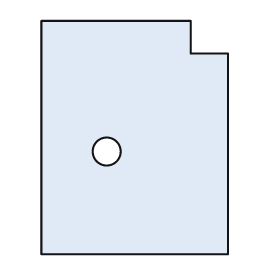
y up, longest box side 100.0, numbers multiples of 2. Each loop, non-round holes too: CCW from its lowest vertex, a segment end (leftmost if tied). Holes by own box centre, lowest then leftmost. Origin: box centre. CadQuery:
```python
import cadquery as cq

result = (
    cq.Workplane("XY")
    .moveTo(-40.0, -50.0)
    .lineTo(40.0, -50.0)
    .lineTo(40.0, 36.0)
    .lineTo(24.0, 36.0)
    .lineTo(24.0, 50.0)
    .lineTo(-40.0, 50.0)
    .close()
    .moveTo(-12.0, -6.0)
    .circle(6.0)
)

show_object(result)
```